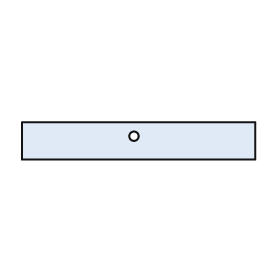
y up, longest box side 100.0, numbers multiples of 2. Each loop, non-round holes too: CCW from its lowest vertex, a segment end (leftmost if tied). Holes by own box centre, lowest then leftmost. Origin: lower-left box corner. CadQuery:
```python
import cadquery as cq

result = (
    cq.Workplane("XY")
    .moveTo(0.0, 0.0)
    .lineTo(100.0, 0.0)
    .lineTo(100.0, 16.0)
    .lineTo(0.0, 16.0)
    .close()
    .moveTo(48.0, 10.0)
    .circle(2.0)
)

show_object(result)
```